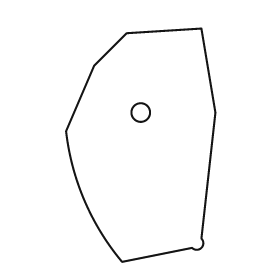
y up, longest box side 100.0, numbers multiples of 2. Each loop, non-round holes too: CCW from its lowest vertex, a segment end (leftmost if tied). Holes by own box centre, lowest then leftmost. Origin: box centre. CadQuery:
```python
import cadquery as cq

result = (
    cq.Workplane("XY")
    .moveTo(-8.0, -50.0)
    .lineTo(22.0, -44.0)
    .threePointArc((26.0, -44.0), (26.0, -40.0))
    .lineTo(32.0, 14.0)
    .lineTo(26.0, 50.0)
    .lineTo(-6.0, 48.0)
    .lineTo(-20.0, 34.0)
    .lineTo(-32.0, 6.0)
    .threePointArc((-24.0, -24.0), (-8.0, -50.0))
    .close()
    .moveTo(0.0, 14.0)
    .circle(4.0)
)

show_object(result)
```